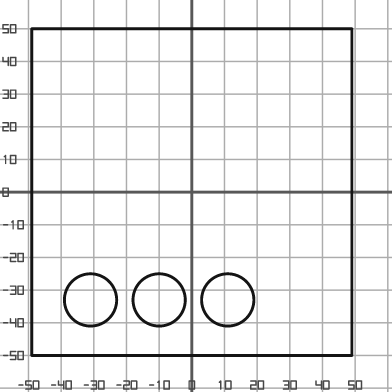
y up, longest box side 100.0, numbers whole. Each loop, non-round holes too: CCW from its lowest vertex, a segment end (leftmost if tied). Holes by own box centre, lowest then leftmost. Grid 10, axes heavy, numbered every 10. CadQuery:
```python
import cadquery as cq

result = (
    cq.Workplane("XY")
    .moveTo(-49.0, -50.0)
    .lineTo(49.0, -50.0)
    .lineTo(49.0, 50.0)
    .lineTo(-49.0, 50.0)
    .close()
    .moveTo(-31.0, -33.0)
    .circle(8.0)
    .moveTo(-10.0, -33.0)
    .circle(8.0)
    .moveTo(11.0, -33.0)
    .circle(8.0)
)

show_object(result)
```